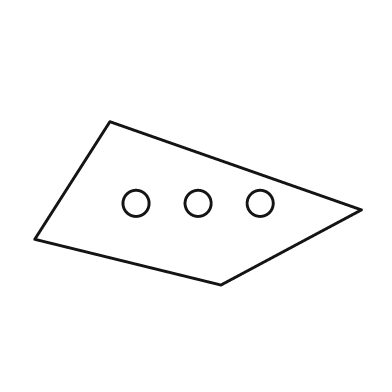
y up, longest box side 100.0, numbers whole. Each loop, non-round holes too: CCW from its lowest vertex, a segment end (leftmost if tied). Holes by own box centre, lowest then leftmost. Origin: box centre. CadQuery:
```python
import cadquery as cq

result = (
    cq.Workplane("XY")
    .moveTo(7.0, -25.0)
    .lineTo(50.0, -2.0)
    .lineTo(-27.0, 25.0)
    .lineTo(-50.0, -11.0)
    .close()
    .moveTo(-19.0, 0.0)
    .circle(4.0)
    .moveTo(0.0, 0.0)
    .circle(4.0)
    .moveTo(19.0, 0.0)
    .circle(4.0)
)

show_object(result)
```